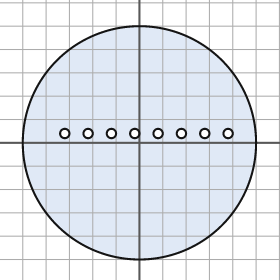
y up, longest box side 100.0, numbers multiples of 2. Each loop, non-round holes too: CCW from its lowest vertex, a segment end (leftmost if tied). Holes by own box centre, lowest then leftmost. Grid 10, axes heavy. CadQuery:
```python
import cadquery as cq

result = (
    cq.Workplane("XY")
    .moveTo(0.0, 0.0)
    .circle(50.0)
    .moveTo(-32.0, 4.0)
    .circle(2.0)
    .moveTo(-22.0, 4.0)
    .circle(2.0)
    .moveTo(-12.0, 4.0)
    .circle(2.0)
    .moveTo(-2.0, 4.0)
    .circle(2.0)
    .moveTo(8.0, 4.0)
    .circle(2.0)
    .moveTo(18.0, 4.0)
    .circle(2.0)
    .moveTo(28.0, 4.0)
    .circle(2.0)
    .moveTo(38.0, 4.0)
    .circle(2.0)
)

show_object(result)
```